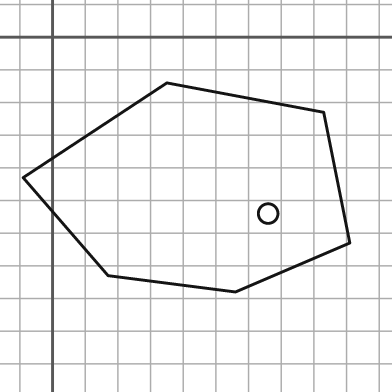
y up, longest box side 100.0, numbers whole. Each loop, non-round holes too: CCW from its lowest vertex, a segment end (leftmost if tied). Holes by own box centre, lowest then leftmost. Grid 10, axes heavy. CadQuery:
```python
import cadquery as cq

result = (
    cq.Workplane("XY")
    .moveTo(56.0, -78.0)
    .lineTo(91.0, -63.0)
    .lineTo(83.0, -23.0)
    .lineTo(35.0, -14.0)
    .lineTo(-9.0, -43.0)
    .lineTo(17.0, -73.0)
    .close()
    .moveTo(66.0, -54.0)
    .circle(3.0)
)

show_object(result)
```